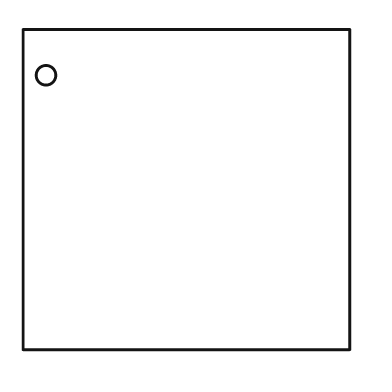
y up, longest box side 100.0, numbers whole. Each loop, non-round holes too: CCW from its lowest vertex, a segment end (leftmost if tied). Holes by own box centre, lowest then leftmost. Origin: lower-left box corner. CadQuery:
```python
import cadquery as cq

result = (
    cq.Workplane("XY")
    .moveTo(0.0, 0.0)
    .lineTo(100.0, 0.0)
    .lineTo(100.0, 98.0)
    .lineTo(0.0, 98.0)
    .close()
    .moveTo(7.0, 84.0)
    .circle(3.0)
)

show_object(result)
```